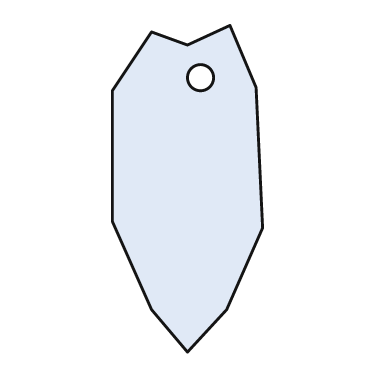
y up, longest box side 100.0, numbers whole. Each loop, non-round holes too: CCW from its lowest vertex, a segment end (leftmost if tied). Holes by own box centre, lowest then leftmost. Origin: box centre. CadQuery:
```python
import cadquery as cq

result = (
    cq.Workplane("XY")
    .moveTo(0.0, -50.0)
    .lineTo(12.0, -37.0)
    .lineTo(23.0, -12.0)
    .lineTo(21.0, 31.0)
    .lineTo(13.0, 50.0)
    .lineTo(0.0, 44.0)
    .lineTo(-11.0, 48.0)
    .lineTo(-23.0, 30.0)
    .lineTo(-23.0, -10.0)
    .lineTo(-11.0, -37.0)
    .close()
    .moveTo(4.0, 34.0)
    .circle(4.0)
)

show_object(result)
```